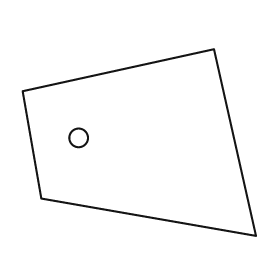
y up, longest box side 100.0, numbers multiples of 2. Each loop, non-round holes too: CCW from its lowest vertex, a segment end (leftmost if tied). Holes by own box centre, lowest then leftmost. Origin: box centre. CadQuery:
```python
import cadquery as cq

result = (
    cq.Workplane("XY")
    .moveTo(50.0, -40.0)
    .lineTo(32.0, 40.0)
    .lineTo(-50.0, 22.0)
    .lineTo(-42.0, -24.0)
    .close()
    .moveTo(-26.0, 2.0)
    .circle(4.0)
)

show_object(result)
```